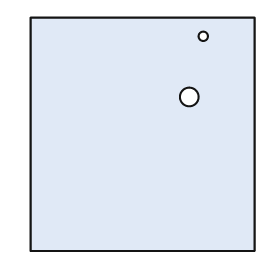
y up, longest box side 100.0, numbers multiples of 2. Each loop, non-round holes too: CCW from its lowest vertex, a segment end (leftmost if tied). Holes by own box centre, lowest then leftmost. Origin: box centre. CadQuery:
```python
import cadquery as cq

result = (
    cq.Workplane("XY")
    .moveTo(-48.0, -50.0)
    .lineTo(48.0, -50.0)
    .lineTo(48.0, 50.0)
    .lineTo(-48.0, 50.0)
    .close()
    .moveTo(20.0, 16.0)
    .circle(4.0)
    .moveTo(26.0, 42.0)
    .circle(2.0)
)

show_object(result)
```